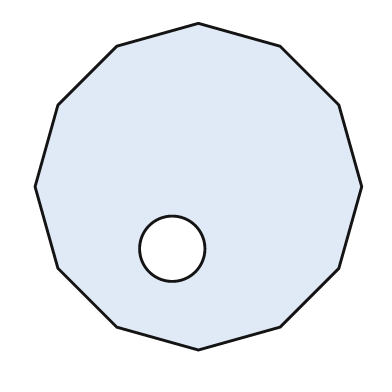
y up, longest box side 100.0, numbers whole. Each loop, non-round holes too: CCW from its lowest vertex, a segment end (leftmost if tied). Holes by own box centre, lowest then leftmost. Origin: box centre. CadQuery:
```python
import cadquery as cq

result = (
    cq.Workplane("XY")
    .moveTo(0.0, -50.0)
    .lineTo(25.0, -43.0)
    .lineTo(43.0, -25.0)
    .lineTo(50.0, 0.0)
    .lineTo(43.0, 25.0)
    .lineTo(25.0, 43.0)
    .lineTo(0.0, 50.0)
    .lineTo(-25.0, 43.0)
    .lineTo(-43.0, 25.0)
    .lineTo(-50.0, 0.0)
    .lineTo(-43.0, -25.0)
    .lineTo(-25.0, -43.0)
    .close()
    .moveTo(-8.0, -19.0)
    .circle(10.0)
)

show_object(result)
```